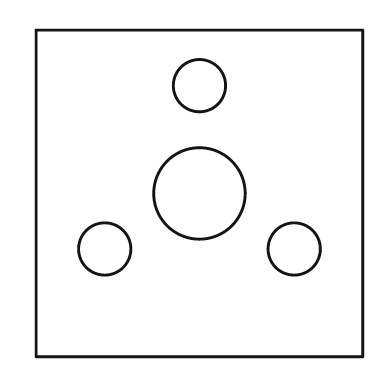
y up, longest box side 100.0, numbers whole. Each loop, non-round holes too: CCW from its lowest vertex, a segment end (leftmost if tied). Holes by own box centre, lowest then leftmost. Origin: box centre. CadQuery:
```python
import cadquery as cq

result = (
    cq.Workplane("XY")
    .moveTo(-50.0, -50.0)
    .lineTo(50.0, -50.0)
    .lineTo(50.0, 50.0)
    .lineTo(-50.0, 50.0)
    .close()
    .moveTo(-29.0, -17.0)
    .circle(8.0)
    .moveTo(29.0, -17.0)
    .circle(8.0)
    .moveTo(0.0, 0.0)
    .circle(14.0)
    .moveTo(0.0, 33.0)
    .circle(8.0)
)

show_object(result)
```